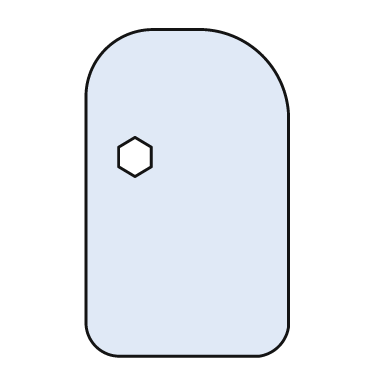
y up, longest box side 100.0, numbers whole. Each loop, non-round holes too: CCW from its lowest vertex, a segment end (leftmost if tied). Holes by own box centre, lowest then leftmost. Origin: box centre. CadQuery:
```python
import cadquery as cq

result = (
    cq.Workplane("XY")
    .moveTo(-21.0, -50.0)
    .lineTo(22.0, -50.0)
    .threePointArc((28.0, -47.0), (31.0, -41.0))
    .lineTo(31.0, 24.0)
    .threePointArc((23.0, 42.0), (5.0, 50.0))
    .lineTo(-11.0, 50.0)
    .threePointArc((-25.0, 44.0), (-31.0, 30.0))
    .lineTo(-31.0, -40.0)
    .threePointArc((-28.0, -47.0), (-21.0, -50.0))
    .close()
    .moveTo(-16.0, 5.0)
    .lineTo(-11.0, 8.0)
    .lineTo(-11.0, 14.0)
    .lineTo(-16.0, 17.0)
    .lineTo(-21.0, 14.0)
    .lineTo(-21.0, 8.0)
    .close()
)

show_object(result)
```